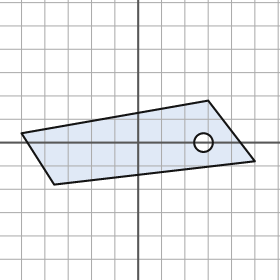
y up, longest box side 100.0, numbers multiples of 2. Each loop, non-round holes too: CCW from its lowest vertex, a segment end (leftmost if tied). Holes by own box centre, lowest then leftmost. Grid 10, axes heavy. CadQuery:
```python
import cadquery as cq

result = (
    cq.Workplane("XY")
    .moveTo(-36.0, -18.0)
    .lineTo(50.0, -8.0)
    .lineTo(30.0, 18.0)
    .lineTo(-50.0, 4.0)
    .close()
    .moveTo(28.0, 0.0)
    .circle(4.0)
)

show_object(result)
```